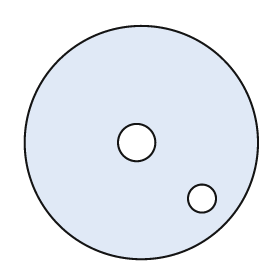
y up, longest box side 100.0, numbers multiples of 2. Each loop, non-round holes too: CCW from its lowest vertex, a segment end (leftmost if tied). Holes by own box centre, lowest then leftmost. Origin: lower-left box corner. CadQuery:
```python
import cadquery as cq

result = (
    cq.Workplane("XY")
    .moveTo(50.0, 50.0)
    .circle(50.0)
    .moveTo(76.0, 26.0)
    .circle(6.0)
    .moveTo(48.0, 50.0)
    .circle(8.0)
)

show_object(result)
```